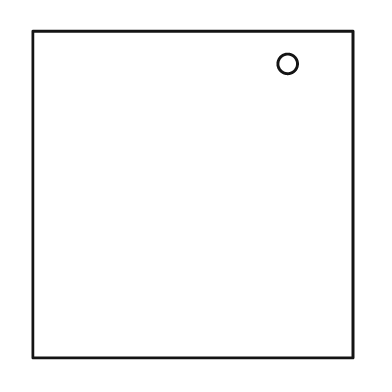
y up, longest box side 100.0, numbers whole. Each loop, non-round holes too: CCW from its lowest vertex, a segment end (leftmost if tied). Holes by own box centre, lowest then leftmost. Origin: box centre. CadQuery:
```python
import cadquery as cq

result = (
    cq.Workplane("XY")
    .moveTo(-49.0, -50.0)
    .lineTo(49.0, -50.0)
    .lineTo(49.0, 50.0)
    .lineTo(-49.0, 50.0)
    .close()
    .moveTo(29.0, 40.0)
    .circle(3.0)
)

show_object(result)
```